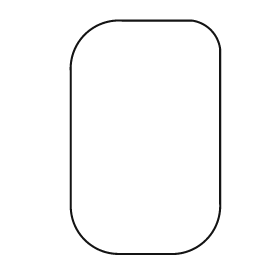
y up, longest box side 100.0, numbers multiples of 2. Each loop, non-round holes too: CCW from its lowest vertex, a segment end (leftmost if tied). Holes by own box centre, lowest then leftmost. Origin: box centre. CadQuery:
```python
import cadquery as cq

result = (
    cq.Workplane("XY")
    .moveTo(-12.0, -50.0)
    .lineTo(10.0, -50.0)
    .threePointArc((26.0, -44.0), (32.0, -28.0))
    .lineTo(32.0, 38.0)
    .threePointArc((28.0, 46.0), (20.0, 50.0))
    .lineTo(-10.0, 50.0)
    .threePointArc((-26.0, 44.0), (-32.0, 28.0))
    .lineTo(-32.0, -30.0)
    .threePointArc((-26.0, -44.0), (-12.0, -50.0))
    .close()
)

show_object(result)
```